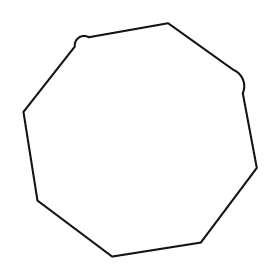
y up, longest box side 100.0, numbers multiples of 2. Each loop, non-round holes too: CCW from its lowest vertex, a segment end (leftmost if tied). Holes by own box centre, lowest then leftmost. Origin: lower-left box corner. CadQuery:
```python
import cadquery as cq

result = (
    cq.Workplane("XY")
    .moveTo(38.0, 0.0)
    .lineTo(76.0, 6.0)
    .lineTo(100.0, 38.0)
    .lineTo(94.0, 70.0)
    .threePointArc((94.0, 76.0), (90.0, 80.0))
    .lineTo(62.0, 100.0)
    .lineTo(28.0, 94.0)
    .threePointArc((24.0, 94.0), (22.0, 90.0))
    .lineTo(0.0, 62.0)
    .lineTo(6.0, 24.0)
    .close()
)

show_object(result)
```